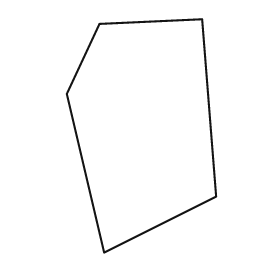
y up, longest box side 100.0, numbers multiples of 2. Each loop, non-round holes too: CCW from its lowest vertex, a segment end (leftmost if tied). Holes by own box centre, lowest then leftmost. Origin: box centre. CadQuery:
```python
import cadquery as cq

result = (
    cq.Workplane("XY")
    .moveTo(-16.0, -50.0)
    .lineTo(32.0, -26.0)
    .lineTo(26.0, 50.0)
    .lineTo(-18.0, 48.0)
    .lineTo(-32.0, 18.0)
    .close()
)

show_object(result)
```